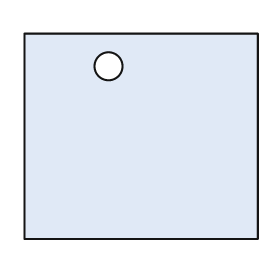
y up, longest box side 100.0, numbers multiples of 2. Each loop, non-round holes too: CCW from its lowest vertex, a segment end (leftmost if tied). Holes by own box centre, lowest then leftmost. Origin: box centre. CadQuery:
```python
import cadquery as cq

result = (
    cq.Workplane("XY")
    .moveTo(-50.0, -44.0)
    .lineTo(50.0, -44.0)
    .lineTo(50.0, 44.0)
    .lineTo(-50.0, 44.0)
    .close()
    .moveTo(-14.0, 30.0)
    .circle(6.0)
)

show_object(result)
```